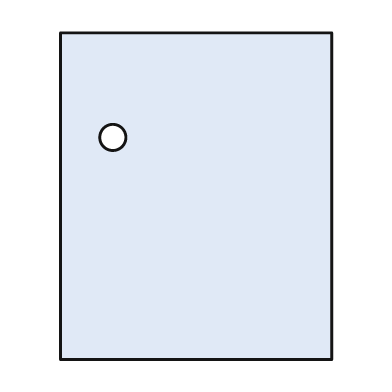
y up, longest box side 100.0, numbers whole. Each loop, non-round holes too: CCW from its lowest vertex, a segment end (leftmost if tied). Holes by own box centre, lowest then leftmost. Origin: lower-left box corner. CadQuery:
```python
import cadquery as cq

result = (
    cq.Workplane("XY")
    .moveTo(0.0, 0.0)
    .lineTo(83.0, 0.0)
    .lineTo(83.0, 100.0)
    .lineTo(0.0, 100.0)
    .close()
    .moveTo(16.0, 68.0)
    .circle(4.0)
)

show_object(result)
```